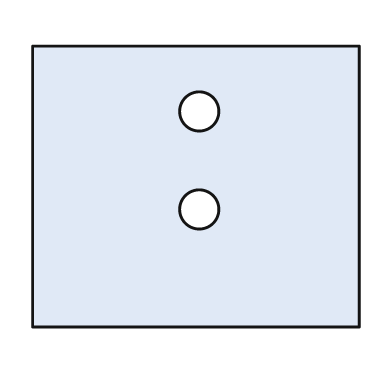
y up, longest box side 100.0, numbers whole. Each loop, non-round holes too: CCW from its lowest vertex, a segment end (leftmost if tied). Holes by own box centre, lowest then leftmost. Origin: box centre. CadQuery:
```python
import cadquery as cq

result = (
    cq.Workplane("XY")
    .moveTo(-50.0, -43.0)
    .lineTo(50.0, -43.0)
    .lineTo(50.0, 43.0)
    .lineTo(-50.0, 43.0)
    .close()
    .moveTo(1.0, -7.0)
    .circle(6.0)
    .moveTo(1.0, 23.0)
    .circle(6.0)
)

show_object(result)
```